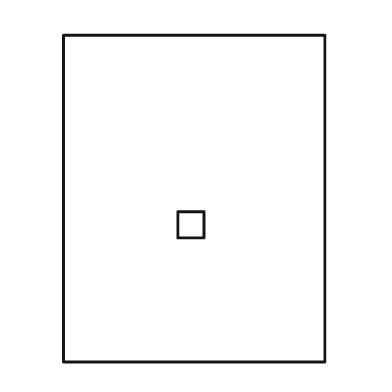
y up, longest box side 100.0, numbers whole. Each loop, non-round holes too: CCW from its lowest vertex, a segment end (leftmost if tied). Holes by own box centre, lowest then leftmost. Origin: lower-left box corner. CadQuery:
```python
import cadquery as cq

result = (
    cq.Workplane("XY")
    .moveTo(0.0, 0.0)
    .lineTo(80.0, 0.0)
    .lineTo(80.0, 100.0)
    .lineTo(0.0, 100.0)
    .close()
    .moveTo(35.0, 38.0)
    .lineTo(43.0, 38.0)
    .lineTo(43.0, 46.0)
    .lineTo(35.0, 46.0)
    .close()
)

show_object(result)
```